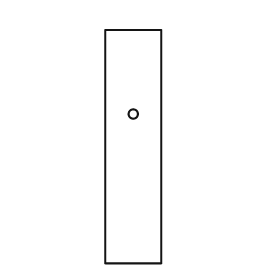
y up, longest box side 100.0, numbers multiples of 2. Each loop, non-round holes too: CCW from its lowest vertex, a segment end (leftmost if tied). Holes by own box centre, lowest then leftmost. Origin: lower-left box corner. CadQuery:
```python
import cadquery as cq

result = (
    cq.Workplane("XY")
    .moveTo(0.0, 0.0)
    .lineTo(24.0, 0.0)
    .lineTo(24.0, 100.0)
    .lineTo(0.0, 100.0)
    .close()
    .moveTo(12.0, 64.0)
    .circle(2.0)
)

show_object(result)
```